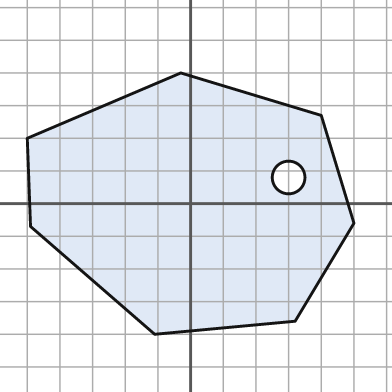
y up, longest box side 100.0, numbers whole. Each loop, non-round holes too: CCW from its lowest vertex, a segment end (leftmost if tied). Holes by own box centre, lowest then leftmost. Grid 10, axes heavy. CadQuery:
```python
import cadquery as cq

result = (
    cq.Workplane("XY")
    .moveTo(-11.0, -40.0)
    .lineTo(32.0, -36.0)
    .lineTo(50.0, -6.0)
    .lineTo(40.0, 27.0)
    .lineTo(-3.0, 40.0)
    .lineTo(-50.0, 20.0)
    .lineTo(-49.0, -7.0)
    .close()
    .moveTo(30.0, 8.0)
    .circle(5.0)
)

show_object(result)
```